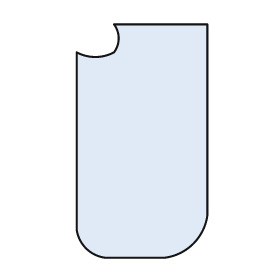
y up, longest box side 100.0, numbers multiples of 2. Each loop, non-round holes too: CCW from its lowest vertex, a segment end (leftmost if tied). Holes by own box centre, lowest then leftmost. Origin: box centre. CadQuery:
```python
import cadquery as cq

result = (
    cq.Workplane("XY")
    .moveTo(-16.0, -50.0)
    .lineTo(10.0, -50.0)
    .threePointArc((22.0, -44.0), (28.0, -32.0))
    .lineTo(28.0, 50.0)
    .lineTo(-12.0, 50.0)
    .threePointArc((-10.0, 44.0), (-12.0, 38.0))
    .threePointArc((-20.0, 36.0), (-28.0, 38.0))
    .lineTo(-28.0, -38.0)
    .threePointArc((-24.0, -46.0), (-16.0, -50.0))
    .close()
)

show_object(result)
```